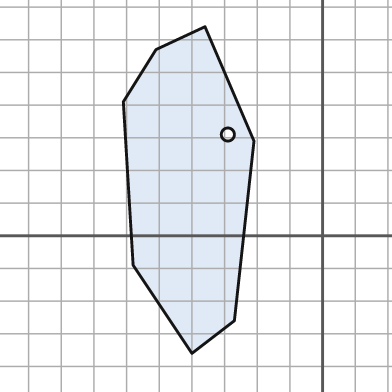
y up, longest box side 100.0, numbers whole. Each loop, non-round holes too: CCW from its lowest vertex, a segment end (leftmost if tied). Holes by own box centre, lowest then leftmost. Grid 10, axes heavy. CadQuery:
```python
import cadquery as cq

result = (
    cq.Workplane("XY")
    .moveTo(-40.0, -36.0)
    .lineTo(-27.0, -26.0)
    .lineTo(-21.0, 29.0)
    .lineTo(-36.0, 64.0)
    .lineTo(-51.0, 57.0)
    .lineTo(-61.0, 41.0)
    .lineTo(-58.0, -9.0)
    .close()
    .moveTo(-29.0, 31.0)
    .circle(2.0)
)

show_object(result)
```